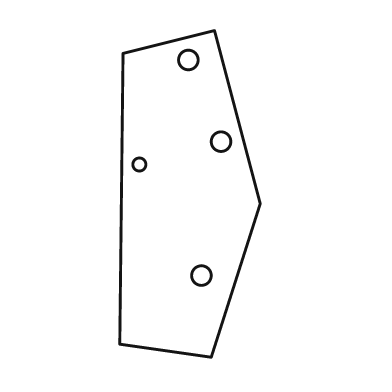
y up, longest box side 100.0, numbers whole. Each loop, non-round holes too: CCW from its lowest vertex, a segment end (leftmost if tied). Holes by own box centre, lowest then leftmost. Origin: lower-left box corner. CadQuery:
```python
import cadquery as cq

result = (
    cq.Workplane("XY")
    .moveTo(28.0, 0.0)
    .lineTo(43.0, 47.0)
    .lineTo(29.0, 100.0)
    .lineTo(1.0, 93.0)
    .lineTo(0.0, 4.0)
    .close()
    .moveTo(25.0, 25.0)
    .circle(3.0)
    .moveTo(6.0, 59.0)
    .circle(2.0)
    .moveTo(31.0, 66.0)
    .circle(3.0)
    .moveTo(21.0, 91.0)
    .circle(3.0)
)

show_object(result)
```